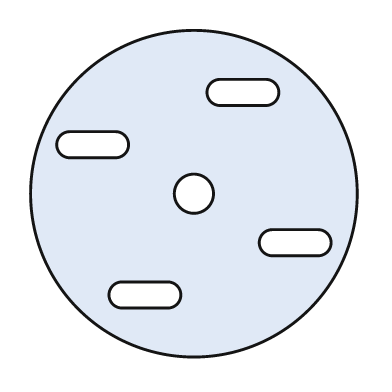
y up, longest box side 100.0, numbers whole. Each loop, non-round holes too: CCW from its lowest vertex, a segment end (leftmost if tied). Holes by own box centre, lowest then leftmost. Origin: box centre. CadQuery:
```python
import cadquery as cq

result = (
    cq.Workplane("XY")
    .moveTo(0.0, 0.0)
    .circle(50.0)
    .moveTo(-22.0, -35.0)
    .lineTo(-8.0, -35.0)
    .threePointArc((-4.0, -31.0), (-8.0, -27.0))
    .lineTo(-22.0, -27.0)
    .threePointArc((-26.0, -31.0), (-22.0, -35.0))
    .close()
    .moveTo(24.0, -19.0)
    .lineTo(38.0, -19.0)
    .threePointArc((42.0, -15.0), (38.0, -11.0))
    .lineTo(24.0, -11.0)
    .threePointArc((20.0, -15.0), (24.0, -19.0))
    .close()
    .moveTo(0.0, 0.0)
    .circle(6.0)
    .moveTo(-38.0, 11.0)
    .lineTo(-24.0, 11.0)
    .threePointArc((-20.0, 15.0), (-24.0, 19.0))
    .lineTo(-38.0, 19.0)
    .threePointArc((-42.0, 15.0), (-38.0, 11.0))
    .close()
    .moveTo(8.0, 27.0)
    .lineTo(22.0, 27.0)
    .threePointArc((26.0, 31.0), (22.0, 35.0))
    .lineTo(8.0, 35.0)
    .threePointArc((4.0, 31.0), (8.0, 27.0))
    .close()
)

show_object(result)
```